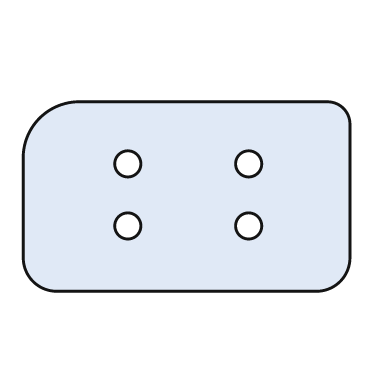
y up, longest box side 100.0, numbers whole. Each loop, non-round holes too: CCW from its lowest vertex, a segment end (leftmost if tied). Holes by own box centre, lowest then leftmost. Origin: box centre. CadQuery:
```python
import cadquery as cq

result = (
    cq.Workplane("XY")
    .moveTo(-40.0, -29.0)
    .lineTo(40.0, -29.0)
    .threePointArc((47.0, -26.0), (50.0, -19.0))
    .lineTo(50.0, 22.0)
    .threePointArc((48.0, 27.0), (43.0, 29.0))
    .lineTo(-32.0, 29.0)
    .threePointArc((-45.0, 24.0), (-50.0, 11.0))
    .lineTo(-50.0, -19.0)
    .threePointArc((-47.0, -26.0), (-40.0, -29.0))
    .close()
    .moveTo(-18.0, -9.0)
    .circle(4.0)
    .moveTo(19.0, -9.0)
    .circle(4.0)
    .moveTo(-18.0, 10.0)
    .circle(4.0)
    .moveTo(19.0, 10.0)
    .circle(4.0)
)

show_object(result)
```